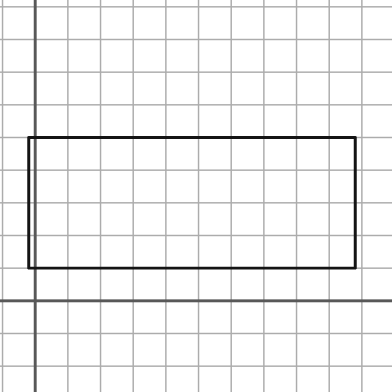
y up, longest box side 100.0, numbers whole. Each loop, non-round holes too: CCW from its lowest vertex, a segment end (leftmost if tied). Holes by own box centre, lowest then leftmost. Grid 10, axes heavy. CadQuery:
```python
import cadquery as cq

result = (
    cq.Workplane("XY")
    .moveTo(-2.0, 10.0)
    .lineTo(98.0, 10.0)
    .lineTo(98.0, 50.0)
    .lineTo(-2.0, 50.0)
    .close()
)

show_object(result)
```